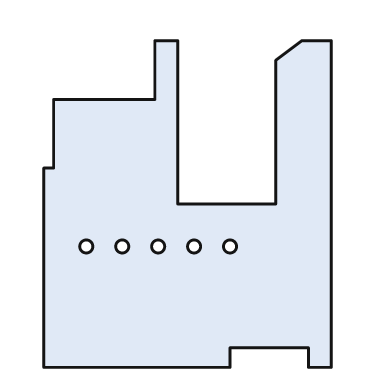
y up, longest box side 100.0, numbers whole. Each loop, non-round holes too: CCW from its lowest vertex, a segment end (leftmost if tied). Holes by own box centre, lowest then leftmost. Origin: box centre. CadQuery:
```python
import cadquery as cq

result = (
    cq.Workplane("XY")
    .moveTo(-44.0, -50.0)
    .lineTo(13.0, -50.0)
    .lineTo(13.0, -44.0)
    .lineTo(37.0, -44.0)
    .lineTo(37.0, -50.0)
    .lineTo(44.0, -50.0)
    .lineTo(44.0, 50.0)
    .lineTo(35.0, 50.0)
    .lineTo(27.0, 44.0)
    .lineTo(27.0, 0.0)
    .lineTo(-3.0, 0.0)
    .lineTo(-3.0, 50.0)
    .lineTo(-10.0, 50.0)
    .lineTo(-10.0, 32.0)
    .lineTo(-41.0, 32.0)
    .lineTo(-41.0, 11.0)
    .lineTo(-44.0, 11.0)
    .close()
    .moveTo(-31.0, -13.0)
    .circle(2.0)
    .moveTo(-20.0, -13.0)
    .circle(2.0)
    .moveTo(-9.0, -13.0)
    .circle(2.0)
    .moveTo(2.0, -13.0)
    .circle(2.0)
    .moveTo(13.0, -13.0)
    .circle(2.0)
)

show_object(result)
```